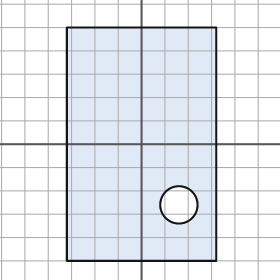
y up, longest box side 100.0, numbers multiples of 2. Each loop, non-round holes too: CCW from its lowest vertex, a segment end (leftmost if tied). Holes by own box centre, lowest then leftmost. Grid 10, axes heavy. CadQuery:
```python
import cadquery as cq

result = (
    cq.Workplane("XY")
    .moveTo(-32.0, -50.0)
    .lineTo(32.0, -50.0)
    .lineTo(32.0, 50.0)
    .lineTo(-32.0, 50.0)
    .close()
    .moveTo(16.0, -26.0)
    .circle(8.0)
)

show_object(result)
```